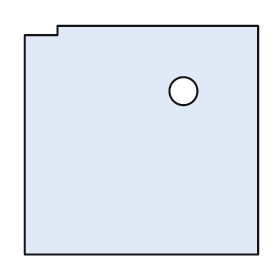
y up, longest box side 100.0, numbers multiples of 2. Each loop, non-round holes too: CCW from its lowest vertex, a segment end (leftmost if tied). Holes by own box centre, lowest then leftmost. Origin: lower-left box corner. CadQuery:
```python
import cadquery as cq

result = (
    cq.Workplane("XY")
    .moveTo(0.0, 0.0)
    .lineTo(100.0, 0.0)
    .lineTo(100.0, 98.0)
    .lineTo(14.0, 98.0)
    .lineTo(14.0, 94.0)
    .lineTo(0.0, 94.0)
    .close()
    .moveTo(68.0, 70.0)
    .circle(6.0)
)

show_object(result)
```